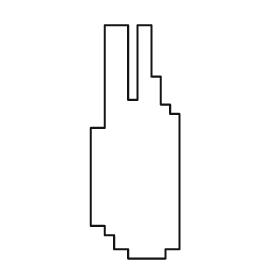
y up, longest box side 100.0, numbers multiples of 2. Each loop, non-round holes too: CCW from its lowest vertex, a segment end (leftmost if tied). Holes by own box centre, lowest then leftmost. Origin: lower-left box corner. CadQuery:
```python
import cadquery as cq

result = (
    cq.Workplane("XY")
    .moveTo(16.0, 0.0)
    .lineTo(32.0, 0.0)
    .lineTo(32.0, 4.0)
    .lineTo(38.0, 4.0)
    .lineTo(38.0, 62.0)
    .lineTo(34.0, 62.0)
    .lineTo(34.0, 66.0)
    .lineTo(30.0, 66.0)
    .lineTo(30.0, 78.0)
    .lineTo(26.0, 78.0)
    .lineTo(26.0, 100.0)
    .lineTo(20.0, 100.0)
    .lineTo(20.0, 68.0)
    .lineTo(16.0, 68.0)
    .lineTo(16.0, 100.0)
    .lineTo(6.0, 100.0)
    .lineTo(6.0, 56.0)
    .lineTo(0.0, 56.0)
    .lineTo(0.0, 14.0)
    .lineTo(6.0, 14.0)
    .lineTo(6.0, 10.0)
    .lineTo(10.0, 10.0)
    .lineTo(10.0, 4.0)
    .lineTo(16.0, 4.0)
    .close()
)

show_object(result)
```